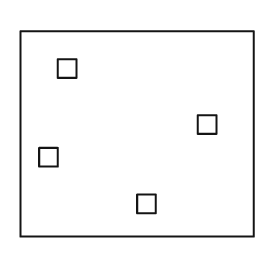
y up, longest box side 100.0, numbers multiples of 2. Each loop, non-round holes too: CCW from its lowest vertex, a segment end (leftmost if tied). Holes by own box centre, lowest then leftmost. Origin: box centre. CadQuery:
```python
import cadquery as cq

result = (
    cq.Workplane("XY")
    .moveTo(-50.0, -44.0)
    .lineTo(50.0, -44.0)
    .lineTo(50.0, 44.0)
    .lineTo(-50.0, 44.0)
    .close()
    .moveTo(0.0, -34.0)
    .lineTo(8.0, -34.0)
    .lineTo(8.0, -26.0)
    .lineTo(0.0, -26.0)
    .close()
    .moveTo(-42.0, -14.0)
    .lineTo(-34.0, -14.0)
    .lineTo(-34.0, -6.0)
    .lineTo(-42.0, -6.0)
    .close()
    .moveTo(26.0, 0.0)
    .lineTo(34.0, 0.0)
    .lineTo(34.0, 8.0)
    .lineTo(26.0, 8.0)
    .close()
    .moveTo(-34.0, 24.0)
    .lineTo(-26.0, 24.0)
    .lineTo(-26.0, 32.0)
    .lineTo(-34.0, 32.0)
    .close()
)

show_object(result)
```